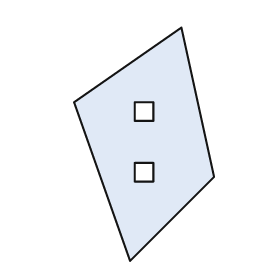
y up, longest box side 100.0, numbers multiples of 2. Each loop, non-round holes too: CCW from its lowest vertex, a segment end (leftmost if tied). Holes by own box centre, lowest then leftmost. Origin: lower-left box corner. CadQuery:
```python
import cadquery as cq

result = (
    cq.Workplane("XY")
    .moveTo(24.0, 0.0)
    .lineTo(60.0, 36.0)
    .lineTo(46.0, 100.0)
    .lineTo(0.0, 68.0)
    .close()
    .moveTo(26.0, 34.0)
    .lineTo(34.0, 34.0)
    .lineTo(34.0, 42.0)
    .lineTo(26.0, 42.0)
    .close()
    .moveTo(26.0, 60.0)
    .lineTo(34.0, 60.0)
    .lineTo(34.0, 68.0)
    .lineTo(26.0, 68.0)
    .close()
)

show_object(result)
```